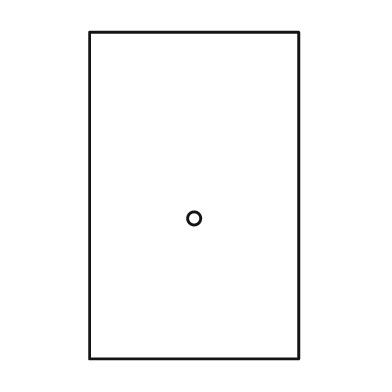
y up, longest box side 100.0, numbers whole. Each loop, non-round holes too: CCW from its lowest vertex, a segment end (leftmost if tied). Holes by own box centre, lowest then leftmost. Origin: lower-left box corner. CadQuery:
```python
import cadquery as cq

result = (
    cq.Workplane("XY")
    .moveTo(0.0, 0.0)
    .lineTo(64.0, 0.0)
    .lineTo(64.0, 100.0)
    .lineTo(0.0, 100.0)
    .close()
    .moveTo(32.0, 43.0)
    .circle(2.0)
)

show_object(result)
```